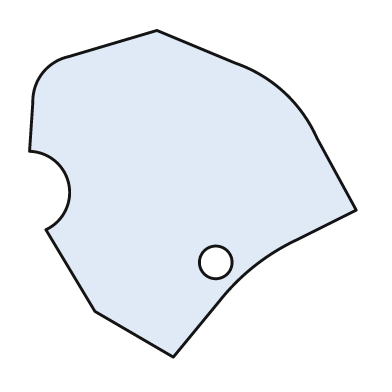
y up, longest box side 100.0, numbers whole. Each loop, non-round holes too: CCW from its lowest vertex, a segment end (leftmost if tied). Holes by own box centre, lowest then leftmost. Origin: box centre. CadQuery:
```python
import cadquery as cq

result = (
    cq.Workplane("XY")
    .moveTo(-6.0, -50.0)
    .lineTo(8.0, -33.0)
    .threePointArc((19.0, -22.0), (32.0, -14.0))
    .lineTo(50.0, -5.0)
    .lineTo(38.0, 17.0)
    .threePointArc((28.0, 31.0), (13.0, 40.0))
    .lineTo(-11.0, 50.0)
    .lineTo(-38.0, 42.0)
    .threePointArc((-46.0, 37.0), (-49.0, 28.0))
    .lineTo(-50.0, 13.0)
    .threePointArc((-38.0, 3.0), (-45.0, -11.0))
    .lineTo(-30.0, -36.0)
    .close()
    .moveTo(7.0, -21.0)
    .circle(5.0)
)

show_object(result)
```